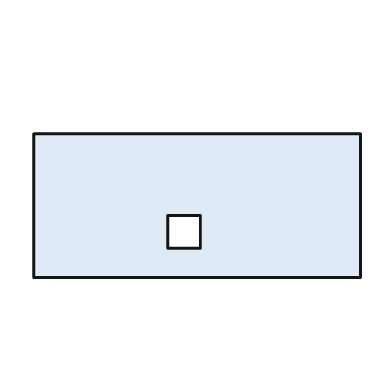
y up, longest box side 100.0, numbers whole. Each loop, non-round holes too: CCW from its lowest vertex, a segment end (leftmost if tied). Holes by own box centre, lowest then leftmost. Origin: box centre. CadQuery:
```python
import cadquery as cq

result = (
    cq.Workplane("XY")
    .moveTo(-50.0, -22.0)
    .lineTo(50.0, -22.0)
    .lineTo(50.0, 22.0)
    .lineTo(-50.0, 22.0)
    .close()
    .moveTo(-9.0, -13.0)
    .lineTo(1.0, -13.0)
    .lineTo(1.0, -3.0)
    .lineTo(-9.0, -3.0)
    .close()
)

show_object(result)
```